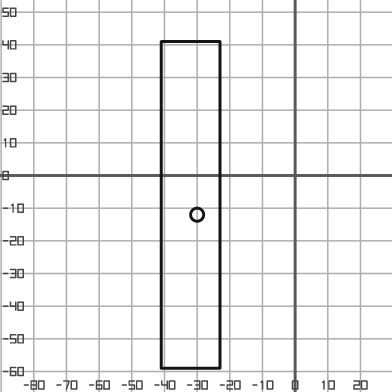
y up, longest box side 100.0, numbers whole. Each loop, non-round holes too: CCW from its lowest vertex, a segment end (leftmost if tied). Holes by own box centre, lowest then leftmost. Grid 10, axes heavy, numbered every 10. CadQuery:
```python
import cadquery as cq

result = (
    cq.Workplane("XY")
    .moveTo(-41.0, -59.0)
    .lineTo(-23.0, -59.0)
    .lineTo(-23.0, 41.0)
    .lineTo(-41.0, 41.0)
    .close()
    .moveTo(-30.0, -12.0)
    .circle(2.0)
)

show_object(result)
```